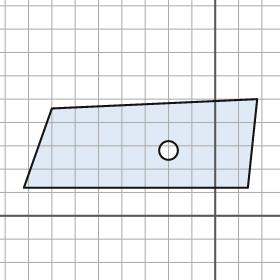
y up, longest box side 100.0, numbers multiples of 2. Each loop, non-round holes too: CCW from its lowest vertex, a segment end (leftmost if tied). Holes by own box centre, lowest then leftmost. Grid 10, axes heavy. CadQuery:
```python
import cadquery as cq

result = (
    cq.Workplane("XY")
    .moveTo(-82.0, 12.0)
    .lineTo(14.0, 12.0)
    .lineTo(18.0, 50.0)
    .lineTo(-70.0, 46.0)
    .close()
    .moveTo(-20.0, 28.0)
    .circle(4.0)
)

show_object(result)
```